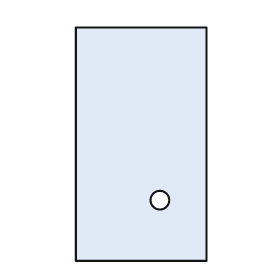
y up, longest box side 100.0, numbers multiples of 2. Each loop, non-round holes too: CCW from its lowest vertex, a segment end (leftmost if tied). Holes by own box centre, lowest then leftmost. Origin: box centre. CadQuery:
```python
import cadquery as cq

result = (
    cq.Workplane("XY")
    .moveTo(-28.0, -50.0)
    .lineTo(28.0, -50.0)
    .lineTo(28.0, 50.0)
    .lineTo(-28.0, 50.0)
    .close()
    .moveTo(8.0, -24.0)
    .circle(4.0)
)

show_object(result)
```